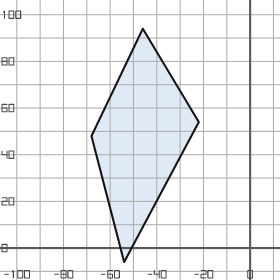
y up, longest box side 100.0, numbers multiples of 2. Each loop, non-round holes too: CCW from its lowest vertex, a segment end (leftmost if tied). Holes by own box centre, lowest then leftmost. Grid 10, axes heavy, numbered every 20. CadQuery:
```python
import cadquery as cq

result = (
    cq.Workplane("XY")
    .moveTo(-54.0, -6.0)
    .lineTo(-22.0, 54.0)
    .lineTo(-46.0, 94.0)
    .lineTo(-68.0, 48.0)
    .close()
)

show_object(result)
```